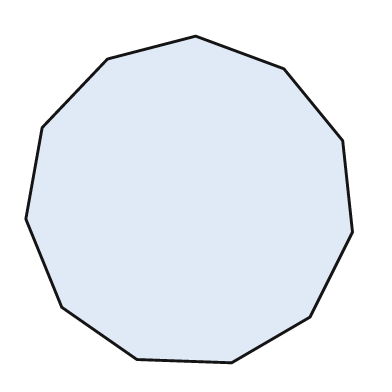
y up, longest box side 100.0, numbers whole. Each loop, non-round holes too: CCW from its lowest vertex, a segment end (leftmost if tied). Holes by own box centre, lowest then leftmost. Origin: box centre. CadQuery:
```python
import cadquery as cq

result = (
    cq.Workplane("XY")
    .moveTo(13.0, -50.0)
    .lineTo(37.0, -36.0)
    .lineTo(50.0, -10.0)
    .lineTo(47.0, 18.0)
    .lineTo(29.0, 40.0)
    .lineTo(2.0, 50.0)
    .lineTo(-25.0, 43.0)
    .lineTo(-45.0, 22.0)
    .lineTo(-50.0, -6.0)
    .lineTo(-39.0, -33.0)
    .lineTo(-16.0, -49.0)
    .close()
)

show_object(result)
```